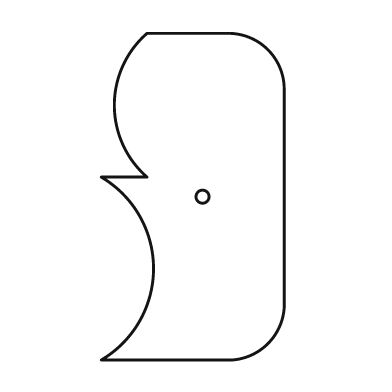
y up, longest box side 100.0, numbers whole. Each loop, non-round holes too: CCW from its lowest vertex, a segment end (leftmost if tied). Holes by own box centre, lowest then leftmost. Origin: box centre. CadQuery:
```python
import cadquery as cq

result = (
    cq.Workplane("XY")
    .moveTo(-28.0, -50.0)
    .lineTo(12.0, -50.0)
    .threePointArc((23.0, -45.0), (28.0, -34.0))
    .lineTo(28.0, 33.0)
    .threePointArc((23.0, 45.0), (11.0, 50.0))
    .lineTo(-14.0, 50.0)
    .threePointArc((-24.0, 28.0), (-14.0, 6.0))
    .lineTo(-28.0, 6.0)
    .threePointArc((-12.0, -22.0), (-28.0, -50.0))
    .close()
    .moveTo(3.0, 0.0)
    .circle(2.0)
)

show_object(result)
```